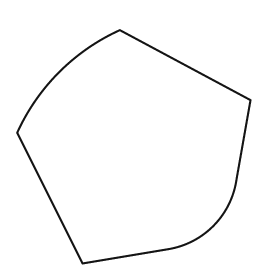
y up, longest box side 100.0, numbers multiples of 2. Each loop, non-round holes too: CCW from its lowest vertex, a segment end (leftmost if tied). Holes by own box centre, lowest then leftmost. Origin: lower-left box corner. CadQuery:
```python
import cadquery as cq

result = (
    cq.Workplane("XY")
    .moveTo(28.0, 0.0)
    .lineTo(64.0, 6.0)
    .threePointArc((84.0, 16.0), (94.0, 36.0))
    .lineTo(100.0, 70.0)
    .lineTo(44.0, 100.0)
    .threePointArc((18.0, 82.0), (0.0, 56.0))
    .close()
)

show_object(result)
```